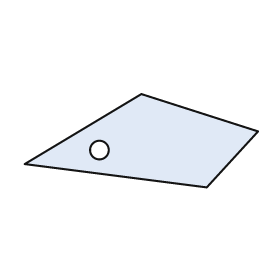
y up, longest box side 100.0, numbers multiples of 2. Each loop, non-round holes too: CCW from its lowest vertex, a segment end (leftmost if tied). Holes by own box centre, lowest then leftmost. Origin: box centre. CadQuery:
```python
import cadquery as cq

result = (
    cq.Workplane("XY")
    .moveTo(28.0, -20.0)
    .lineTo(50.0, 4.0)
    .lineTo(0.0, 20.0)
    .lineTo(-50.0, -10.0)
    .close()
    .moveTo(-18.0, -4.0)
    .circle(4.0)
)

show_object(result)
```